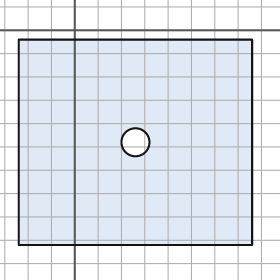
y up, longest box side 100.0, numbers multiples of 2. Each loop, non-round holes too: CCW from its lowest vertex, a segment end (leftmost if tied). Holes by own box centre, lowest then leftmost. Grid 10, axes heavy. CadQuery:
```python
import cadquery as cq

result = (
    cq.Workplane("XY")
    .moveTo(-24.0, -92.0)
    .lineTo(76.0, -92.0)
    .lineTo(76.0, -4.0)
    .lineTo(-24.0, -4.0)
    .close()
    .moveTo(26.0, -48.0)
    .circle(6.0)
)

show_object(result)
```